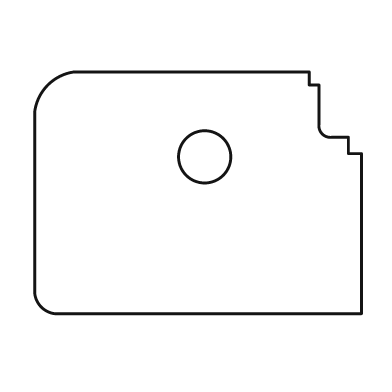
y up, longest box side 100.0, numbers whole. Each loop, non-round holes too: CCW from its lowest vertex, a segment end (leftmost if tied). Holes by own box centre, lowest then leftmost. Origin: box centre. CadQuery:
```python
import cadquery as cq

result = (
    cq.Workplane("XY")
    .moveTo(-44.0, -37.0)
    .lineTo(50.0, -37.0)
    .lineTo(50.0, 12.0)
    .lineTo(46.0, 12.0)
    .lineTo(46.0, 17.0)
    .lineTo(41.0, 17.0)
    .threePointArc((38.0, 18.0), (37.0, 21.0))
    .lineTo(37.0, 33.0)
    .lineTo(34.0, 33.0)
    .lineTo(34.0, 37.0)
    .lineTo(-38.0, 37.0)
    .threePointArc((-46.0, 33.0), (-50.0, 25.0))
    .lineTo(-50.0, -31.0)
    .threePointArc((-48.0, -35.0), (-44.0, -37.0))
    .close()
    .moveTo(2.0, 11.0)
    .circle(8.0)
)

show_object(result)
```